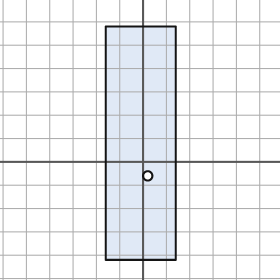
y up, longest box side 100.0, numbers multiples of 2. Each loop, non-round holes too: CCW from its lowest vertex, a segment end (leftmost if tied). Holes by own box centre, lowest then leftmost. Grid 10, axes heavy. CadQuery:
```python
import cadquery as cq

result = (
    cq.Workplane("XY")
    .moveTo(-16.0, -42.0)
    .lineTo(14.0, -42.0)
    .lineTo(14.0, 58.0)
    .lineTo(-16.0, 58.0)
    .close()
    .moveTo(2.0, -6.0)
    .circle(2.0)
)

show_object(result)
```